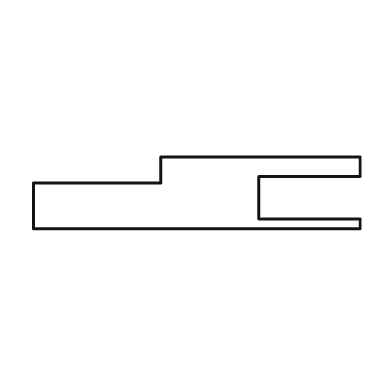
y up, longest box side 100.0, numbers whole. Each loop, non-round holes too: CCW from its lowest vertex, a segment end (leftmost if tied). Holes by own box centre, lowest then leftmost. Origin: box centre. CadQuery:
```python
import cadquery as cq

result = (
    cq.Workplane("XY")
    .moveTo(-50.0, -11.0)
    .lineTo(50.0, -11.0)
    .lineTo(50.0, -8.0)
    .lineTo(19.0, -8.0)
    .lineTo(19.0, 5.0)
    .lineTo(50.0, 5.0)
    .lineTo(50.0, 11.0)
    .lineTo(-11.0, 11.0)
    .lineTo(-11.0, 3.0)
    .lineTo(-50.0, 3.0)
    .close()
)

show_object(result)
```